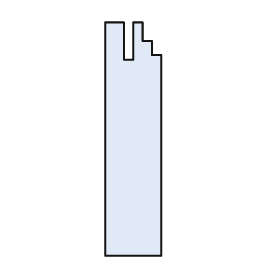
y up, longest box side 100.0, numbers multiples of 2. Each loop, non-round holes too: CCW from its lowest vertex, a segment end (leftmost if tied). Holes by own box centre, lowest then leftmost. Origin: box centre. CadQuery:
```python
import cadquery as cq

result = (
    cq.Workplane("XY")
    .moveTo(-12.0, -50.0)
    .lineTo(12.0, -50.0)
    .lineTo(12.0, 36.0)
    .lineTo(8.0, 36.0)
    .lineTo(8.0, 42.0)
    .lineTo(4.0, 42.0)
    .lineTo(4.0, 50.0)
    .lineTo(0.0, 50.0)
    .lineTo(0.0, 34.0)
    .lineTo(-4.0, 34.0)
    .lineTo(-4.0, 50.0)
    .lineTo(-12.0, 50.0)
    .close()
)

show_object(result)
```